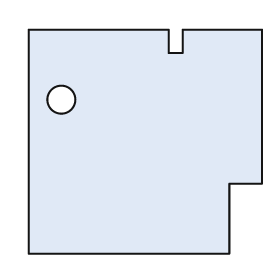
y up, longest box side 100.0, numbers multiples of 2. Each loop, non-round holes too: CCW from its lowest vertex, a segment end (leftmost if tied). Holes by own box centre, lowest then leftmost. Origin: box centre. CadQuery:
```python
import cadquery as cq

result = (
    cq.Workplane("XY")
    .moveTo(-50.0, -48.0)
    .lineTo(36.0, -48.0)
    .lineTo(36.0, -18.0)
    .lineTo(50.0, -18.0)
    .lineTo(50.0, 48.0)
    .lineTo(16.0, 48.0)
    .lineTo(16.0, 38.0)
    .lineTo(10.0, 38.0)
    .lineTo(10.0, 48.0)
    .lineTo(-50.0, 48.0)
    .close()
    .moveTo(-36.0, 18.0)
    .circle(6.0)
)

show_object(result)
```